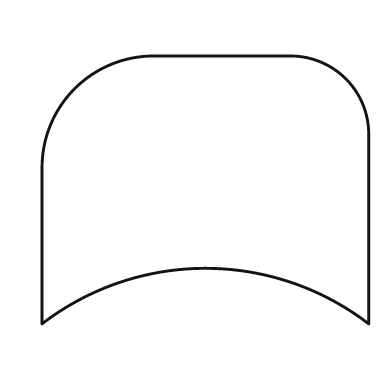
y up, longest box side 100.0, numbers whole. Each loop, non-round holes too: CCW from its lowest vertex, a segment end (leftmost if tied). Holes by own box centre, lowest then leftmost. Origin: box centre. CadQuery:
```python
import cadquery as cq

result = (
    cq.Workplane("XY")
    .moveTo(-50.0, -41.0)
    .threePointArc((0.0, -24.0), (50.0, -41.0))
    .lineTo(50.0, 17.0)
    .threePointArc((43.0, 34.0), (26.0, 41.0))
    .lineTo(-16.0, 41.0)
    .threePointArc((-40.0, 31.0), (-50.0, 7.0))
    .close()
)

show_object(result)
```